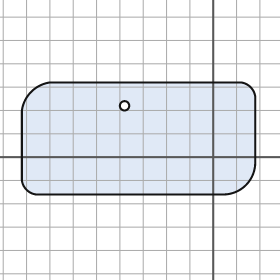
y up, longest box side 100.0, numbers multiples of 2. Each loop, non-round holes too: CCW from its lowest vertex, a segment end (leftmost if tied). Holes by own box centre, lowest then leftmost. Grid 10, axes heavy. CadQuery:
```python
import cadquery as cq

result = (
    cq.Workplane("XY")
    .moveTo(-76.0, -16.0)
    .lineTo(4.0, -16.0)
    .threePointArc((14.0, -12.0), (18.0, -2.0))
    .lineTo(18.0, 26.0)
    .threePointArc((16.0, 30.0), (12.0, 32.0))
    .lineTo(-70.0, 32.0)
    .threePointArc((-78.0, 28.0), (-82.0, 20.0))
    .lineTo(-82.0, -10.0)
    .threePointArc((-80.0, -14.0), (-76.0, -16.0))
    .close()
    .moveTo(-38.0, 22.0)
    .circle(2.0)
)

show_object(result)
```